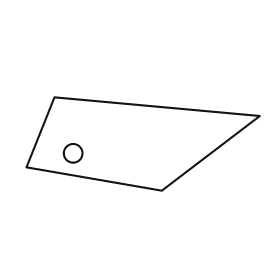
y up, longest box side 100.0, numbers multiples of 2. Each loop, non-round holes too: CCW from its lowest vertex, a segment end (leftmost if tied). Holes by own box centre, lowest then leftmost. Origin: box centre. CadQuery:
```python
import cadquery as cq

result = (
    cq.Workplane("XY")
    .moveTo(8.0, -20.0)
    .lineTo(50.0, 12.0)
    .lineTo(-38.0, 20.0)
    .lineTo(-50.0, -10.0)
    .close()
    .moveTo(-30.0, -4.0)
    .circle(4.0)
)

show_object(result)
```